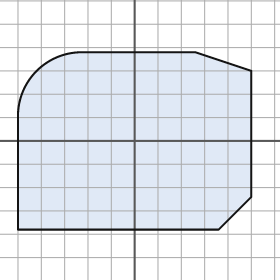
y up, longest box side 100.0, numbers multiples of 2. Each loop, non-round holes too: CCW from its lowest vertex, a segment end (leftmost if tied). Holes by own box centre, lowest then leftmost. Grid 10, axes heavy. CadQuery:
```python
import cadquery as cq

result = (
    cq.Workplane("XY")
    .moveTo(-50.0, -38.0)
    .lineTo(36.0, -38.0)
    .lineTo(50.0, -24.0)
    .lineTo(50.0, 30.0)
    .lineTo(26.0, 38.0)
    .lineTo(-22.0, 38.0)
    .threePointArc((-42.0, 30.0), (-50.0, 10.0))
    .close()
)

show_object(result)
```